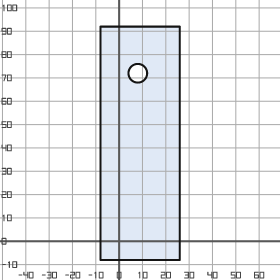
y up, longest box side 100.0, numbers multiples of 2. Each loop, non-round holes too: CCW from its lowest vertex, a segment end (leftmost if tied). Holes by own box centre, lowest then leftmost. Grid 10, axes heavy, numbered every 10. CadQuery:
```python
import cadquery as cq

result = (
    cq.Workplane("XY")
    .moveTo(-8.0, -8.0)
    .lineTo(26.0, -8.0)
    .lineTo(26.0, 92.0)
    .lineTo(-8.0, 92.0)
    .close()
    .moveTo(8.0, 72.0)
    .circle(4.0)
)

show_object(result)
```